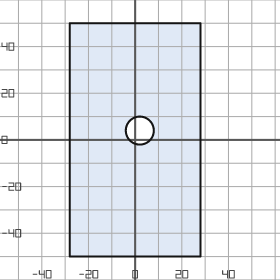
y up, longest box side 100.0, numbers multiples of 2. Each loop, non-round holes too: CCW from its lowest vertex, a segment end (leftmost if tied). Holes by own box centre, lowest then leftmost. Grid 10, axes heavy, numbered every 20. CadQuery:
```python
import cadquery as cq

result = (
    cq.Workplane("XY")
    .moveTo(-28.0, -50.0)
    .lineTo(28.0, -50.0)
    .lineTo(28.0, 50.0)
    .lineTo(-28.0, 50.0)
    .close()
    .moveTo(2.0, 4.0)
    .circle(6.0)
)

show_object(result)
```